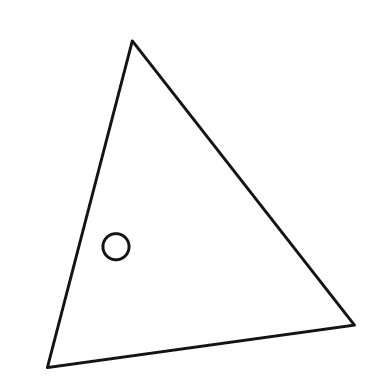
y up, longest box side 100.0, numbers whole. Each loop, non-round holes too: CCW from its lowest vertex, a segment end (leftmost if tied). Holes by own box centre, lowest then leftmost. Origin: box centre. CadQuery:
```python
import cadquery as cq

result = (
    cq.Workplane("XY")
    .moveTo(-47.0, -50.0)
    .lineTo(47.0, -37.0)
    .lineTo(-21.0, 50.0)
    .close()
    .moveTo(-26.0, -13.0)
    .circle(4.0)
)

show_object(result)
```